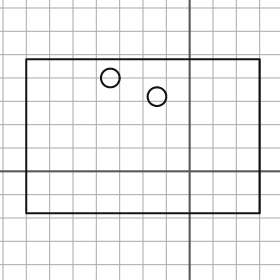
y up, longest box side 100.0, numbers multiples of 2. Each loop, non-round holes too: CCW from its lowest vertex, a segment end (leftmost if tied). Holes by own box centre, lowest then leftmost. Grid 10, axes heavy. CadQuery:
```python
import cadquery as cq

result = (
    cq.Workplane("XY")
    .moveTo(-70.0, -18.0)
    .lineTo(30.0, -18.0)
    .lineTo(30.0, 48.0)
    .lineTo(-70.0, 48.0)
    .close()
    .moveTo(-14.0, 32.0)
    .circle(4.0)
    .moveTo(-34.0, 40.0)
    .circle(4.0)
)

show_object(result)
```